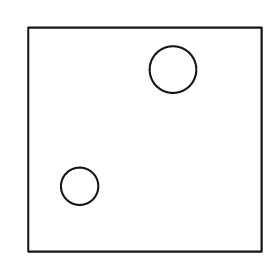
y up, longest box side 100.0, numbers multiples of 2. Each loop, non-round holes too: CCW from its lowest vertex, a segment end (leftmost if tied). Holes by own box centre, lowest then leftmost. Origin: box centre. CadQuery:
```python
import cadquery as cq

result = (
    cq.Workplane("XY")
    .moveTo(-50.0, -48.0)
    .lineTo(50.0, -48.0)
    .lineTo(50.0, 48.0)
    .lineTo(-50.0, 48.0)
    .close()
    .moveTo(-28.0, -20.0)
    .circle(8.0)
    .moveTo(12.0, 30.0)
    .circle(10.0)
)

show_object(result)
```